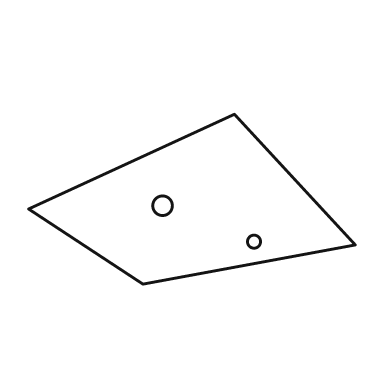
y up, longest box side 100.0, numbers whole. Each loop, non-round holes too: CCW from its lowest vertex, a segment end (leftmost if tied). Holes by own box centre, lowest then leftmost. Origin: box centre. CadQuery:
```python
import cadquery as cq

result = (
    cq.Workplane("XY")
    .moveTo(-15.0, -26.0)
    .lineTo(50.0, -14.0)
    .lineTo(13.0, 26.0)
    .lineTo(-50.0, -3.0)
    .close()
    .moveTo(19.0, -13.0)
    .circle(2.0)
    .moveTo(-9.0, -2.0)
    .circle(3.0)
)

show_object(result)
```